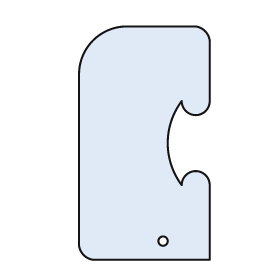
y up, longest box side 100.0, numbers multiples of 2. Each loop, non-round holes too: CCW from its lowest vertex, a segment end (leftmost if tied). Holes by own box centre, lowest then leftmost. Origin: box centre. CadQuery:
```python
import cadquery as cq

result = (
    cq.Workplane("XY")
    .moveTo(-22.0, -50.0)
    .lineTo(28.0, -50.0)
    .lineTo(28.0, -18.0)
    .threePointArc((22.0, -12.0), (16.0, -18.0))
    .threePointArc((10.0, 0.0), (16.0, 18.0))
    .threePointArc((22.0, 12.0), (28.0, 18.0))
    .lineTo(28.0, 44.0)
    .threePointArc((26.0, 48.0), (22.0, 50.0))
    .lineTo(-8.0, 50.0)
    .threePointArc((-22.0, 44.0), (-28.0, 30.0))
    .lineTo(-28.0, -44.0)
    .threePointArc((-26.0, -48.0), (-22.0, -50.0))
    .close()
    .moveTo(8.0, -42.0)
    .circle(2.0)
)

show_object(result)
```